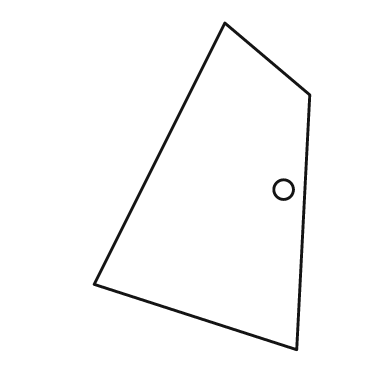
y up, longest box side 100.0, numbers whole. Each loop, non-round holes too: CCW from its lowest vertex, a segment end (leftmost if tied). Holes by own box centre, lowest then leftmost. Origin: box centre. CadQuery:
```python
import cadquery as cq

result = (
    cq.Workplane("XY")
    .moveTo(29.0, -50.0)
    .lineTo(33.0, 28.0)
    .lineTo(7.0, 50.0)
    .lineTo(-33.0, -30.0)
    .close()
    .moveTo(25.0, -1.0)
    .circle(3.0)
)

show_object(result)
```